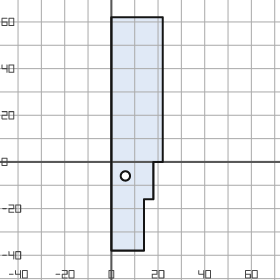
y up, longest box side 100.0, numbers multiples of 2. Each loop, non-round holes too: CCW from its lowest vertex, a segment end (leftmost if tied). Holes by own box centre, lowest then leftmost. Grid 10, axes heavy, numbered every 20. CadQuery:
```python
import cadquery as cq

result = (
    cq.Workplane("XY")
    .moveTo(0.0, -38.0)
    .lineTo(14.0, -38.0)
    .lineTo(14.0, -16.0)
    .lineTo(18.0, -16.0)
    .lineTo(18.0, 0.0)
    .lineTo(22.0, 0.0)
    .lineTo(22.0, 62.0)
    .lineTo(0.0, 62.0)
    .close()
    .moveTo(6.0, -6.0)
    .circle(2.0)
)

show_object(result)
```